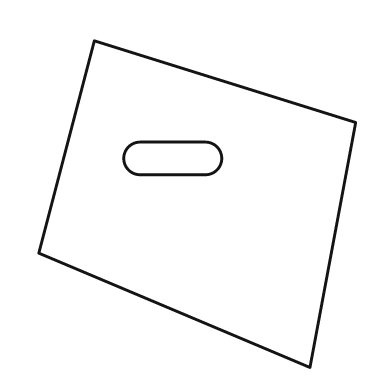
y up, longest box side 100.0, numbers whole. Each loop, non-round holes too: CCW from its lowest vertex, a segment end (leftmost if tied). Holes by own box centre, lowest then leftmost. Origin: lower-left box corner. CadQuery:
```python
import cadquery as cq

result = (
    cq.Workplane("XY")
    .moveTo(83.0, 0.0)
    .lineTo(97.0, 75.0)
    .lineTo(17.0, 100.0)
    .lineTo(0.0, 35.0)
    .close()
    .moveTo(31.0, 59.0)
    .lineTo(51.0, 59.0)
    .threePointArc((56.0, 64.0), (51.0, 69.0))
    .lineTo(31.0, 69.0)
    .threePointArc((26.0, 64.0), (31.0, 59.0))
    .close()
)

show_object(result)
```